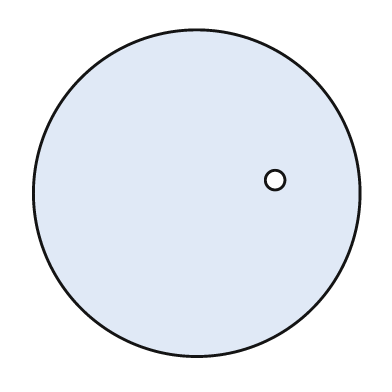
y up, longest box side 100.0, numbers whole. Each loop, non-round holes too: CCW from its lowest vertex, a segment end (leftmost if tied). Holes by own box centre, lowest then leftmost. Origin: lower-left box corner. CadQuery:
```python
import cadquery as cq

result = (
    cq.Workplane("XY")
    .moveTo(50.0, 50.0)
    .circle(50.0)
    .moveTo(74.0, 54.0)
    .circle(3.0)
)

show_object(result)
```